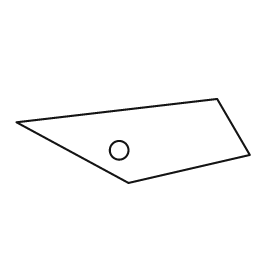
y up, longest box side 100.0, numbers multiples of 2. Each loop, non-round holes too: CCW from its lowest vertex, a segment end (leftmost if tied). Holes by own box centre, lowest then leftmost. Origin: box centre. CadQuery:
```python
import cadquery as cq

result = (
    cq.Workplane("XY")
    .moveTo(-2.0, -18.0)
    .lineTo(50.0, -6.0)
    .lineTo(36.0, 18.0)
    .lineTo(-50.0, 8.0)
    .close()
    .moveTo(-6.0, -4.0)
    .circle(4.0)
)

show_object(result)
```